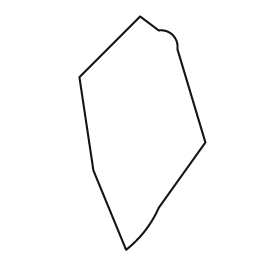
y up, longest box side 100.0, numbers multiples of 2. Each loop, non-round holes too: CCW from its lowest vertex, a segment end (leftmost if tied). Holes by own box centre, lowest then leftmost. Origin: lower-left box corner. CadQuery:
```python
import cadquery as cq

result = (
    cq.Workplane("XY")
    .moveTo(20.0, 0.0)
    .threePointArc((28.0, 8.0), (34.0, 18.0))
    .lineTo(54.0, 46.0)
    .lineTo(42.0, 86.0)
    .threePointArc((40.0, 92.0), (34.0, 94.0))
    .lineTo(26.0, 100.0)
    .lineTo(0.0, 74.0)
    .lineTo(6.0, 34.0)
    .close()
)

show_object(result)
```